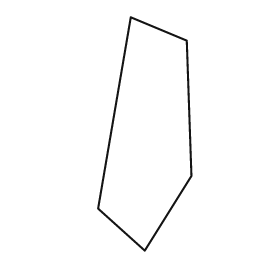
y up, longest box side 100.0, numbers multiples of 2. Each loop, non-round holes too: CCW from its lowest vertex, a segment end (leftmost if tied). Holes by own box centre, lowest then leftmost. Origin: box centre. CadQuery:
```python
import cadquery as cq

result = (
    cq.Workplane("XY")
    .moveTo(0.0, -50.0)
    .lineTo(20.0, -18.0)
    .lineTo(18.0, 40.0)
    .lineTo(-6.0, 50.0)
    .lineTo(-20.0, -32.0)
    .close()
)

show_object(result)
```